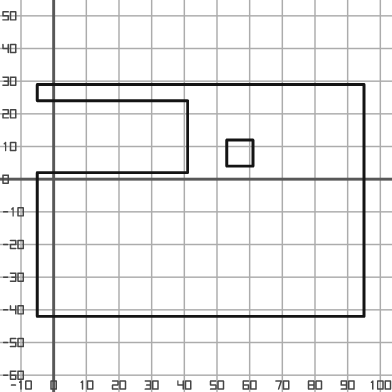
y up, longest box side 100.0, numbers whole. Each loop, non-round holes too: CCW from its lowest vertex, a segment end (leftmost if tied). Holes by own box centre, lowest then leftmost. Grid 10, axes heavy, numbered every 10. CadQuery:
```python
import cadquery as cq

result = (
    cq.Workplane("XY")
    .moveTo(-5.0, -42.0)
    .lineTo(95.0, -42.0)
    .lineTo(95.0, 29.0)
    .lineTo(-5.0, 29.0)
    .lineTo(-5.0, 24.0)
    .lineTo(41.0, 24.0)
    .lineTo(41.0, 2.0)
    .lineTo(-5.0, 2.0)
    .close()
    .moveTo(53.0, 4.0)
    .lineTo(61.0, 4.0)
    .lineTo(61.0, 12.0)
    .lineTo(53.0, 12.0)
    .close()
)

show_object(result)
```